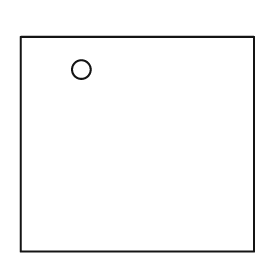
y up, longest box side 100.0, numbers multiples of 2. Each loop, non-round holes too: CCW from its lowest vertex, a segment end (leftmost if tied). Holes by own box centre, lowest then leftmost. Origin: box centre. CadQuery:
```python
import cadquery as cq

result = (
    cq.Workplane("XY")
    .moveTo(-50.0, -46.0)
    .lineTo(50.0, -46.0)
    .lineTo(50.0, 46.0)
    .lineTo(-50.0, 46.0)
    .close()
    .moveTo(-24.0, 32.0)
    .circle(4.0)
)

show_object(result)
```